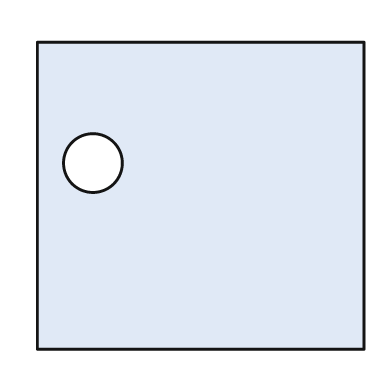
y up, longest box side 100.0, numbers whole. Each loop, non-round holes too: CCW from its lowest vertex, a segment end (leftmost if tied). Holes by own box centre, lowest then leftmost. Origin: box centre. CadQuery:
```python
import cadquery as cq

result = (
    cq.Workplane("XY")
    .moveTo(-50.0, -47.0)
    .lineTo(50.0, -47.0)
    .lineTo(50.0, 47.0)
    .lineTo(-50.0, 47.0)
    .close()
    .moveTo(-33.0, 10.0)
    .circle(9.0)
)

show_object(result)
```